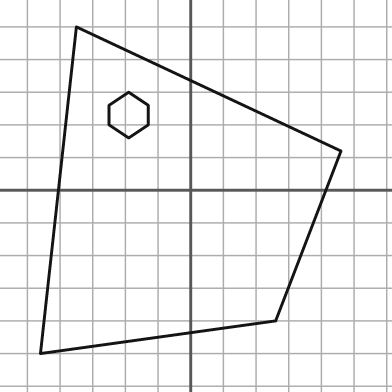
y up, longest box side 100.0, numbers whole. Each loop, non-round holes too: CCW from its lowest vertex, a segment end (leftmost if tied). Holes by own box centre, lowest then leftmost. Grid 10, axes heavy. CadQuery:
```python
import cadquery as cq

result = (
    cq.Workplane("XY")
    .moveTo(-46.0, -50.0)
    .lineTo(26.0, -40.0)
    .lineTo(46.0, 12.0)
    .lineTo(-35.0, 50.0)
    .close()
    .moveTo(-19.0, 16.0)
    .lineTo(-13.0, 20.0)
    .lineTo(-13.0, 26.0)
    .lineTo(-19.0, 30.0)
    .lineTo(-25.0, 26.0)
    .lineTo(-25.0, 20.0)
    .close()
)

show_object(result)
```